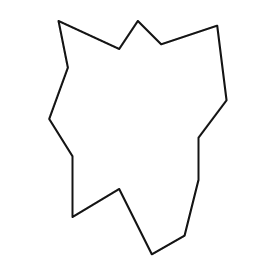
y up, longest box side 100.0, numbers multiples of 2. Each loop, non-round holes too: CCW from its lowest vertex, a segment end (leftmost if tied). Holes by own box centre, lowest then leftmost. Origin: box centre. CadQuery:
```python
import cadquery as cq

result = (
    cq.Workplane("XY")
    .moveTo(6.0, -50.0)
    .lineTo(20.0, -42.0)
    .lineTo(26.0, -18.0)
    .lineTo(26.0, 0.0)
    .lineTo(38.0, 16.0)
    .lineTo(34.0, 48.0)
    .lineTo(10.0, 40.0)
    .lineTo(0.0, 50.0)
    .lineTo(-8.0, 38.0)
    .lineTo(-34.0, 50.0)
    .lineTo(-30.0, 30.0)
    .lineTo(-38.0, 8.0)
    .lineTo(-28.0, -8.0)
    .lineTo(-28.0, -34.0)
    .lineTo(-8.0, -22.0)
    .close()
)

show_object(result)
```